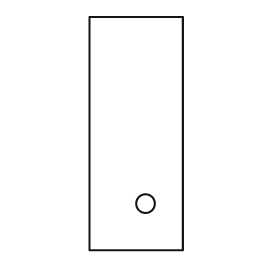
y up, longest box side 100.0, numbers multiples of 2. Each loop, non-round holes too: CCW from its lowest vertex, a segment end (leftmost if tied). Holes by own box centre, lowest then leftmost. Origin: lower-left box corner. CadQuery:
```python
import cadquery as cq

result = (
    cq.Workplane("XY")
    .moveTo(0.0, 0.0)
    .lineTo(40.0, 0.0)
    .lineTo(40.0, 100.0)
    .lineTo(0.0, 100.0)
    .close()
    .moveTo(24.0, 20.0)
    .circle(4.0)
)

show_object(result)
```